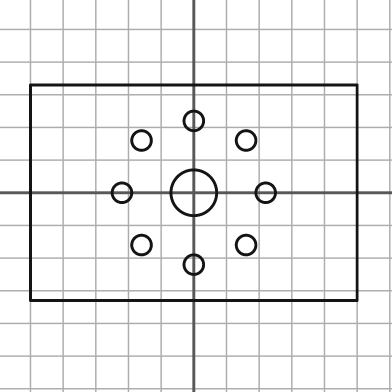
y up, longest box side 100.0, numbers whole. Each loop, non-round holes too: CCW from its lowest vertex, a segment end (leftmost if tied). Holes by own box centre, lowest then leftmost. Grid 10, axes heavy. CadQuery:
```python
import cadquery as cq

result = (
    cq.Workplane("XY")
    .moveTo(-50.0, -33.0)
    .lineTo(50.0, -33.0)
    .lineTo(50.0, 33.0)
    .lineTo(-50.0, 33.0)
    .close()
    .moveTo(0.0, -22.0)
    .circle(3.0)
    .moveTo(-16.0, -16.0)
    .circle(3.0)
    .moveTo(16.0, -16.0)
    .circle(3.0)
    .moveTo(-22.0, 0.0)
    .circle(3.0)
    .moveTo(0.0, 0.0)
    .circle(7.0)
    .moveTo(22.0, 0.0)
    .circle(3.0)
    .moveTo(-16.0, 16.0)
    .circle(3.0)
    .moveTo(16.0, 16.0)
    .circle(3.0)
    .moveTo(0.0, 22.0)
    .circle(3.0)
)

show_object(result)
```